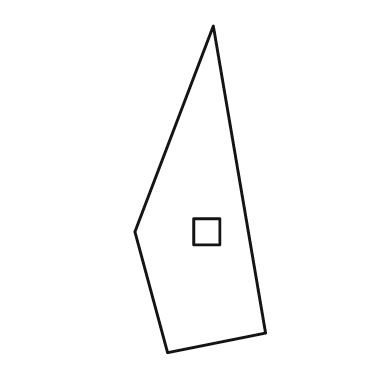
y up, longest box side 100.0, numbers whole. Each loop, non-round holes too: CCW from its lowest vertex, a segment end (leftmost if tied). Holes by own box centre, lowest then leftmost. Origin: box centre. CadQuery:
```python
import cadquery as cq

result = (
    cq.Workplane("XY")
    .moveTo(-10.0, -50.0)
    .lineTo(20.0, -44.0)
    .lineTo(4.0, 50.0)
    .lineTo(-20.0, -13.0)
    .close()
    .moveTo(-2.0, -17.0)
    .lineTo(6.0, -17.0)
    .lineTo(6.0, -9.0)
    .lineTo(-2.0, -9.0)
    .close()
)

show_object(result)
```